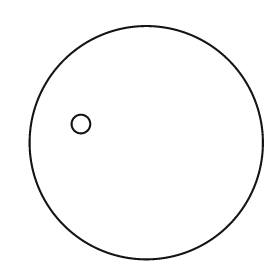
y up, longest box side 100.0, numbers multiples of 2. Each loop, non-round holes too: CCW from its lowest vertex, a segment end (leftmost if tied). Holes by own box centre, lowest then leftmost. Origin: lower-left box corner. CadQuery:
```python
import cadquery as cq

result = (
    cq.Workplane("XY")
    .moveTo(50.0, 50.0)
    .circle(50.0)
    .moveTo(22.0, 58.0)
    .circle(4.0)
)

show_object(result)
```